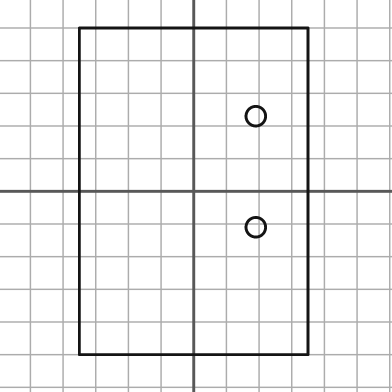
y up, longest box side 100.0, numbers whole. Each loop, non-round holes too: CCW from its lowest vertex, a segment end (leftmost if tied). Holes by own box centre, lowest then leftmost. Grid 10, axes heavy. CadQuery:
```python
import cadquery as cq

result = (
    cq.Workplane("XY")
    .moveTo(-35.0, -50.0)
    .lineTo(35.0, -50.0)
    .lineTo(35.0, 50.0)
    .lineTo(-35.0, 50.0)
    .close()
    .moveTo(19.0, -11.0)
    .circle(3.0)
    .moveTo(19.0, 23.0)
    .circle(3.0)
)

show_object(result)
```